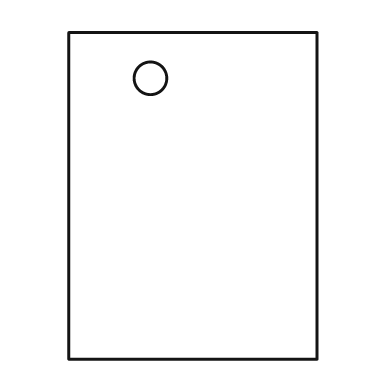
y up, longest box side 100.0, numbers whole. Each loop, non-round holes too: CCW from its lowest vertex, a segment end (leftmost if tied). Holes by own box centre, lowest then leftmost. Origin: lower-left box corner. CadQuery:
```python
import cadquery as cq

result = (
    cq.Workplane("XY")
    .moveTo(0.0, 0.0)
    .lineTo(76.0, 0.0)
    .lineTo(76.0, 100.0)
    .lineTo(0.0, 100.0)
    .close()
    .moveTo(25.0, 86.0)
    .circle(5.0)
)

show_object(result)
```